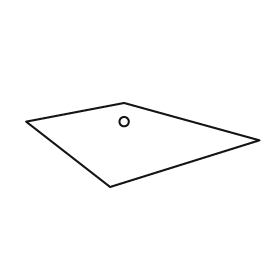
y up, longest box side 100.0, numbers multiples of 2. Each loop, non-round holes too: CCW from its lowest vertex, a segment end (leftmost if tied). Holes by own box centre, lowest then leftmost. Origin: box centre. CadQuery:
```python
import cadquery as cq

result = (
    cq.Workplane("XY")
    .moveTo(-14.0, -18.0)
    .lineTo(50.0, 2.0)
    .lineTo(-8.0, 18.0)
    .lineTo(-50.0, 10.0)
    .close()
    .moveTo(-8.0, 10.0)
    .circle(2.0)
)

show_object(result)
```